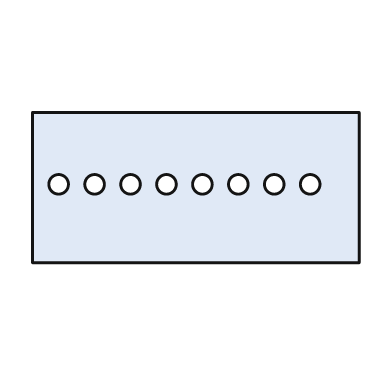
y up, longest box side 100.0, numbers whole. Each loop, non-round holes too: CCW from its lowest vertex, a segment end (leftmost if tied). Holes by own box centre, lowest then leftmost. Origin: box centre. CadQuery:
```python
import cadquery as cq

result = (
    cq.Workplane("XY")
    .moveTo(-50.0, -23.0)
    .lineTo(50.0, -23.0)
    .lineTo(50.0, 23.0)
    .lineTo(-50.0, 23.0)
    .close()
    .moveTo(-42.0, 1.0)
    .circle(3.0)
    .moveTo(-31.0, 1.0)
    .circle(3.0)
    .moveTo(-20.0, 1.0)
    .circle(3.0)
    .moveTo(-9.0, 1.0)
    .circle(3.0)
    .moveTo(2.0, 1.0)
    .circle(3.0)
    .moveTo(13.0, 1.0)
    .circle(3.0)
    .moveTo(24.0, 1.0)
    .circle(3.0)
    .moveTo(35.0, 1.0)
    .circle(3.0)
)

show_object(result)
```